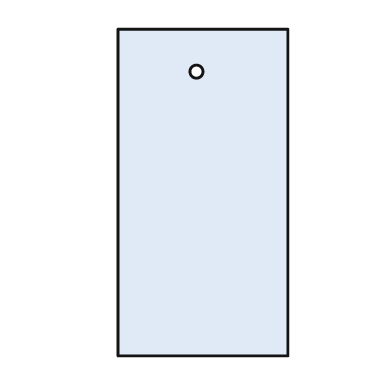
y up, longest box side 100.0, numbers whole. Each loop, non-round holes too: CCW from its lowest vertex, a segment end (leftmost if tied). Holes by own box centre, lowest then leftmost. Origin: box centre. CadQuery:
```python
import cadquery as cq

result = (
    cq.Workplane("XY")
    .moveTo(-26.0, -50.0)
    .lineTo(26.0, -50.0)
    .lineTo(26.0, 50.0)
    .lineTo(-26.0, 50.0)
    .close()
    .moveTo(-2.0, 37.0)
    .circle(2.0)
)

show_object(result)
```